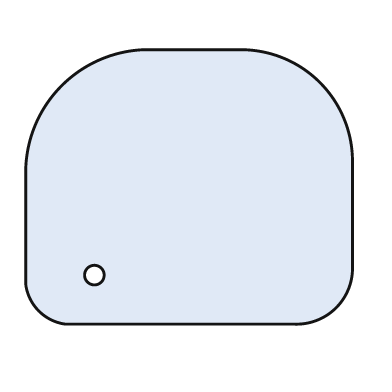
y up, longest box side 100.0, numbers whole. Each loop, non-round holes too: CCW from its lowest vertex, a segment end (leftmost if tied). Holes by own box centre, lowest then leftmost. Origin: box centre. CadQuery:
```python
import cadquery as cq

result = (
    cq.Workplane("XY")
    .moveTo(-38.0, -42.0)
    .lineTo(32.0, -42.0)
    .threePointArc((45.0, -37.0), (50.0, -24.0))
    .lineTo(50.0, 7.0)
    .threePointArc((40.0, 32.0), (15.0, 42.0))
    .lineTo(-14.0, 42.0)
    .threePointArc((-39.0, 31.0), (-50.0, 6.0))
    .lineTo(-50.0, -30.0)
    .threePointArc((-46.0, -38.0), (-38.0, -42.0))
    .close()
    .moveTo(-29.0, -27.0)
    .circle(3.0)
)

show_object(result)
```